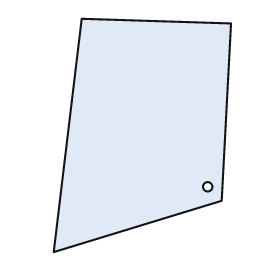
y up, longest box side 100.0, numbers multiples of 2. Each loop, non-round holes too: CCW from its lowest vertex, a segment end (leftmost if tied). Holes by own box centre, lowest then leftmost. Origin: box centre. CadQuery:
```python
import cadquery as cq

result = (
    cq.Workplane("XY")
    .moveTo(-38.0, -50.0)
    .lineTo(34.0, -28.0)
    .lineTo(38.0, 48.0)
    .lineTo(-26.0, 50.0)
    .close()
    .moveTo(28.0, -22.0)
    .circle(2.0)
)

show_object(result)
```